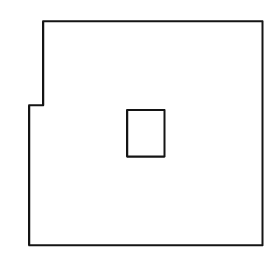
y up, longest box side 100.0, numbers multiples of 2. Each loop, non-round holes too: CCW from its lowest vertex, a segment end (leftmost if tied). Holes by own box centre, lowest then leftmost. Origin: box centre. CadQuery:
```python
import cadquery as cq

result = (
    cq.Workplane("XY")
    .moveTo(-50.0, -48.0)
    .lineTo(50.0, -48.0)
    .lineTo(50.0, 48.0)
    .lineTo(-44.0, 48.0)
    .lineTo(-44.0, 12.0)
    .lineTo(-50.0, 12.0)
    .close()
    .moveTo(-8.0, -10.0)
    .lineTo(8.0, -10.0)
    .lineTo(8.0, 10.0)
    .lineTo(-8.0, 10.0)
    .close()
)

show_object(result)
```